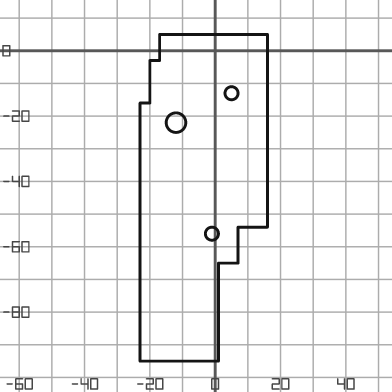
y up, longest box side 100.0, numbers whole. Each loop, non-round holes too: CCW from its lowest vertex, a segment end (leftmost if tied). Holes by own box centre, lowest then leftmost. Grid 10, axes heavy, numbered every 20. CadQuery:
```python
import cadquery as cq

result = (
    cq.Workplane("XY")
    .moveTo(-23.0, -95.0)
    .lineTo(1.0, -95.0)
    .lineTo(1.0, -65.0)
    .lineTo(7.0, -65.0)
    .lineTo(7.0, -54.0)
    .lineTo(16.0, -54.0)
    .lineTo(16.0, 5.0)
    .lineTo(-17.0, 5.0)
    .lineTo(-17.0, -3.0)
    .lineTo(-20.0, -3.0)
    .lineTo(-20.0, -16.0)
    .lineTo(-23.0, -16.0)
    .close()
    .moveTo(-1.0, -56.0)
    .circle(2.0)
    .moveTo(-12.0, -22.0)
    .circle(3.0)
    .moveTo(5.0, -13.0)
    .circle(2.0)
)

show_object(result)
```